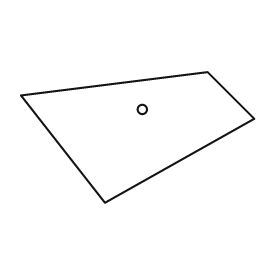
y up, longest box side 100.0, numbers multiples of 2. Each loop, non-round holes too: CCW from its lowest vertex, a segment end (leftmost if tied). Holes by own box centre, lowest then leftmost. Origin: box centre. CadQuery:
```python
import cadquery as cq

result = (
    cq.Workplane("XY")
    .moveTo(-14.0, -28.0)
    .lineTo(50.0, 8.0)
    .lineTo(30.0, 28.0)
    .lineTo(-50.0, 18.0)
    .close()
    .moveTo(2.0, 12.0)
    .circle(2.0)
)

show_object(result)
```